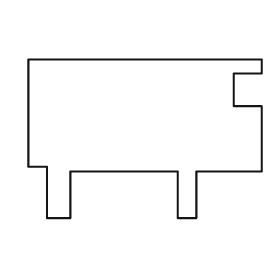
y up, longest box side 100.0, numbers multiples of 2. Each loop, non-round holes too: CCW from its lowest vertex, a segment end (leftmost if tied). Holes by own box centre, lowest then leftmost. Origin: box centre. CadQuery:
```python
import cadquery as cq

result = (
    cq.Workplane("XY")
    .moveTo(-42.0, -34.0)
    .lineTo(-32.0, -34.0)
    .lineTo(-32.0, -14.0)
    .lineTo(14.0, -14.0)
    .lineTo(14.0, -34.0)
    .lineTo(22.0, -34.0)
    .lineTo(22.0, -14.0)
    .lineTo(50.0, -14.0)
    .lineTo(50.0, 14.0)
    .lineTo(38.0, 14.0)
    .lineTo(38.0, 28.0)
    .lineTo(50.0, 28.0)
    .lineTo(50.0, 34.0)
    .lineTo(-50.0, 34.0)
    .lineTo(-50.0, -12.0)
    .lineTo(-42.0, -12.0)
    .close()
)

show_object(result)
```